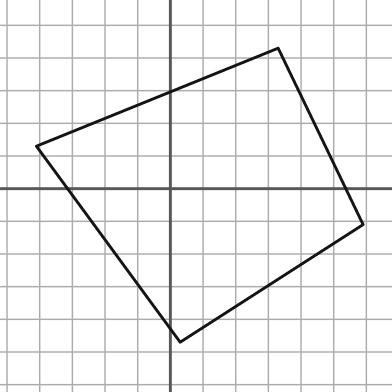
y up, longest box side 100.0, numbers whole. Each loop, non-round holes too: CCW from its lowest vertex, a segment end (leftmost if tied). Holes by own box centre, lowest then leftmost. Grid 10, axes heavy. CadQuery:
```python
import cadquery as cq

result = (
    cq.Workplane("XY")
    .moveTo(3.0, -47.0)
    .lineTo(59.0, -11.0)
    .lineTo(33.0, 43.0)
    .lineTo(-41.0, 13.0)
    .close()
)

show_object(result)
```